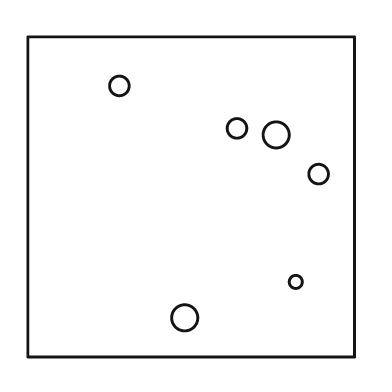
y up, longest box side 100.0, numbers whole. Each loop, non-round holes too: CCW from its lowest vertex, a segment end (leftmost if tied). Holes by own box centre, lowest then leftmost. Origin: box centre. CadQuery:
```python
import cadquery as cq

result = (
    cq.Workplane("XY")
    .moveTo(-50.0, -49.0)
    .lineTo(50.0, -49.0)
    .lineTo(50.0, 49.0)
    .lineTo(-50.0, 49.0)
    .close()
    .moveTo(-2.0, -37.0)
    .circle(4.0)
    .moveTo(32.0, -26.0)
    .circle(2.0)
    .moveTo(39.0, 7.0)
    .circle(3.0)
    .moveTo(26.0, 19.0)
    .circle(4.0)
    .moveTo(14.0, 21.0)
    .circle(3.0)
    .moveTo(-22.0, 34.0)
    .circle(3.0)
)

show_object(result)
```